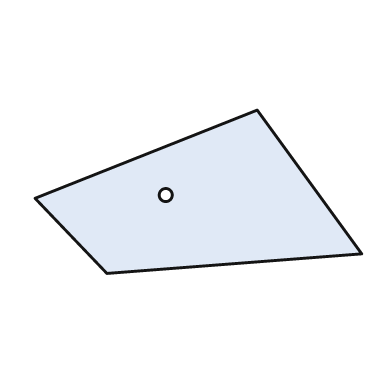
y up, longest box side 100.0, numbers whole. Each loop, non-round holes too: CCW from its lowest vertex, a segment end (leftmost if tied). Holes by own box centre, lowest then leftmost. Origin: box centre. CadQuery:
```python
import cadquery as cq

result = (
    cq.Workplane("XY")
    .moveTo(-28.0, -25.0)
    .lineTo(50.0, -19.0)
    .lineTo(18.0, 25.0)
    .lineTo(-50.0, -2.0)
    .close()
    .moveTo(-10.0, -1.0)
    .circle(2.0)
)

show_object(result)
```